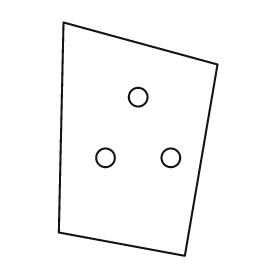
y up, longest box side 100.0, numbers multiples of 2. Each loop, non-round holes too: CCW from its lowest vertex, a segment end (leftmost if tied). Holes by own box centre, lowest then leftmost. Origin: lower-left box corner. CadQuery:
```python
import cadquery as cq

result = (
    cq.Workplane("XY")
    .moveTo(54.0, 0.0)
    .lineTo(68.0, 82.0)
    .lineTo(2.0, 100.0)
    .lineTo(0.0, 10.0)
    .close()
    .moveTo(20.0, 42.0)
    .circle(4.0)
    .moveTo(48.0, 42.0)
    .circle(4.0)
    .moveTo(34.0, 68.0)
    .circle(4.0)
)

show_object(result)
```